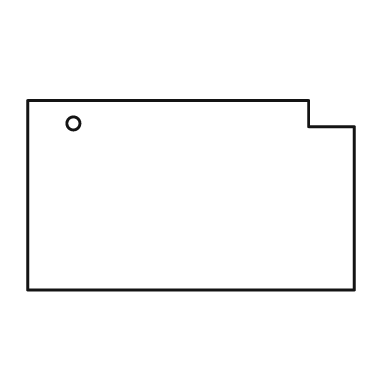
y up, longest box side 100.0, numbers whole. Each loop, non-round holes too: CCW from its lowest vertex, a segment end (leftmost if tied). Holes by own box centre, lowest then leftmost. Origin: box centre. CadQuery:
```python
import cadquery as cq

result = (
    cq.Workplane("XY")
    .moveTo(-50.0, -29.0)
    .lineTo(50.0, -29.0)
    .lineTo(50.0, 21.0)
    .lineTo(36.0, 21.0)
    .lineTo(36.0, 29.0)
    .lineTo(-50.0, 29.0)
    .close()
    .moveTo(-36.0, 22.0)
    .circle(2.0)
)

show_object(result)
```